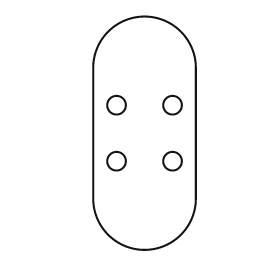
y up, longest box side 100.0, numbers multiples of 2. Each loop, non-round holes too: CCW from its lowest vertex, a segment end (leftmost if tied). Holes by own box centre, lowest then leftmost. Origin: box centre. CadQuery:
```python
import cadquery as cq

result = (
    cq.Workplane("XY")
    .moveTo(-22.0, -28.0)
    .threePointArc((0.0, -50.0), (22.0, -28.0))
    .lineTo(22.0, 28.0)
    .threePointArc((0.0, 50.0), (-22.0, 28.0))
    .close()
    .moveTo(-12.0, -12.0)
    .circle(4.0)
    .moveTo(12.0, -12.0)
    .circle(4.0)
    .moveTo(-12.0, 12.0)
    .circle(4.0)
    .moveTo(12.0, 12.0)
    .circle(4.0)
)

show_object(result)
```